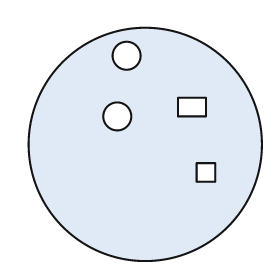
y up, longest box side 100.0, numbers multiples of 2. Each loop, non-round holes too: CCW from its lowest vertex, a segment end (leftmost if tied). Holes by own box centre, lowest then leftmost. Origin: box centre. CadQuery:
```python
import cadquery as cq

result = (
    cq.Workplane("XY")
    .moveTo(0.0, 0.0)
    .circle(50.0)
    .moveTo(22.0, -16.0)
    .lineTo(30.0, -16.0)
    .lineTo(30.0, -8.0)
    .lineTo(22.0, -8.0)
    .close()
    .moveTo(-12.0, 12.0)
    .circle(6.0)
    .moveTo(14.0, 12.0)
    .lineTo(26.0, 12.0)
    .lineTo(26.0, 20.0)
    .lineTo(14.0, 20.0)
    .close()
    .moveTo(-8.0, 38.0)
    .circle(6.0)
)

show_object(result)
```